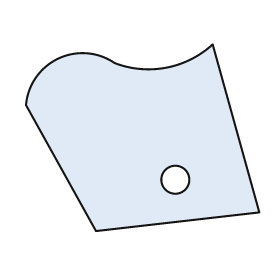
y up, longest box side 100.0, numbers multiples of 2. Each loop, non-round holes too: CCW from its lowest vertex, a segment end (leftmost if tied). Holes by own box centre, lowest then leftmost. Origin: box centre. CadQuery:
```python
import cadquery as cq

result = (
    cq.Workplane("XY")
    .moveTo(-20.0, -40.0)
    .lineTo(50.0, -32.0)
    .lineTo(30.0, 40.0)
    .threePointArc((10.0, 30.0), (-12.0, 32.0))
    .threePointArc((-36.0, 34.0), (-50.0, 14.0))
    .close()
    .moveTo(14.0, -18.0)
    .circle(6.0)
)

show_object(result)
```